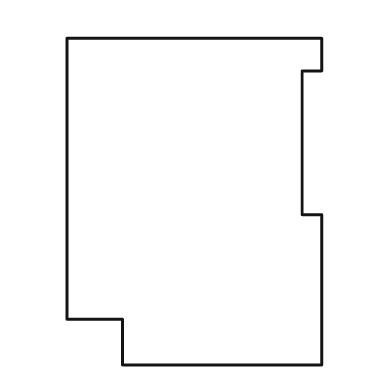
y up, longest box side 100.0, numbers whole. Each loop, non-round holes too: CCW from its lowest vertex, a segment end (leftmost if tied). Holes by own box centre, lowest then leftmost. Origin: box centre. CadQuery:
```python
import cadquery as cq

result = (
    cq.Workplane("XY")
    .moveTo(-22.0, -50.0)
    .lineTo(39.0, -50.0)
    .lineTo(39.0, -4.0)
    .lineTo(33.0, -4.0)
    .lineTo(33.0, 40.0)
    .lineTo(39.0, 40.0)
    .lineTo(39.0, 50.0)
    .lineTo(-39.0, 50.0)
    .lineTo(-39.0, -36.0)
    .lineTo(-22.0, -36.0)
    .close()
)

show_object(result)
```